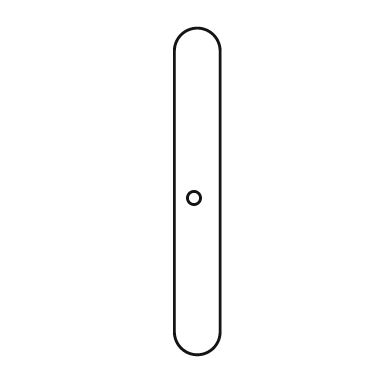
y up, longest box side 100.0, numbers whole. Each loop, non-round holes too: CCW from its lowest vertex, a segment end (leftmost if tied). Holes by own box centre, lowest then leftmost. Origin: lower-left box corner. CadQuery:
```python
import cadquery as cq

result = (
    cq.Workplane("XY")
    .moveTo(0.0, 7.0)
    .threePointArc((7.0, 0.0), (14.0, 7.0))
    .lineTo(14.0, 93.0)
    .threePointArc((7.0, 100.0), (0.0, 93.0))
    .close()
    .moveTo(6.0, 48.0)
    .circle(2.0)
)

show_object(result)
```